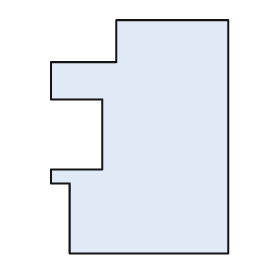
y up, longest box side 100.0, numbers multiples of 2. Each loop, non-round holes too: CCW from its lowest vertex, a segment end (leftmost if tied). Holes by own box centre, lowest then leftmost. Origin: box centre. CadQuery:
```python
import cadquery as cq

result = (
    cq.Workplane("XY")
    .moveTo(-30.0, -50.0)
    .lineTo(38.0, -50.0)
    .lineTo(38.0, 50.0)
    .lineTo(-10.0, 50.0)
    .lineTo(-10.0, 32.0)
    .lineTo(-38.0, 32.0)
    .lineTo(-38.0, 16.0)
    .lineTo(-16.0, 16.0)
    .lineTo(-16.0, -14.0)
    .lineTo(-38.0, -14.0)
    .lineTo(-38.0, -20.0)
    .lineTo(-30.0, -20.0)
    .close()
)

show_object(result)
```